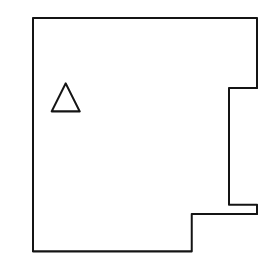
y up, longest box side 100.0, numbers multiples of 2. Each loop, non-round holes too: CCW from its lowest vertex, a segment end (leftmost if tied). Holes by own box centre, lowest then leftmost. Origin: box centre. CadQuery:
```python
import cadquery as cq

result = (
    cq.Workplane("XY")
    .moveTo(-48.0, -50.0)
    .lineTo(20.0, -50.0)
    .lineTo(20.0, -34.0)
    .lineTo(48.0, -34.0)
    .lineTo(48.0, -30.0)
    .lineTo(36.0, -30.0)
    .lineTo(36.0, 20.0)
    .lineTo(48.0, 20.0)
    .lineTo(48.0, 50.0)
    .lineTo(-48.0, 50.0)
    .close()
    .moveTo(-40.0, 10.0)
    .lineTo(-28.0, 10.0)
    .lineTo(-34.0, 22.0)
    .close()
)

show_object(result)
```